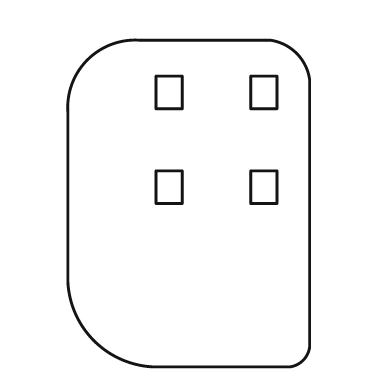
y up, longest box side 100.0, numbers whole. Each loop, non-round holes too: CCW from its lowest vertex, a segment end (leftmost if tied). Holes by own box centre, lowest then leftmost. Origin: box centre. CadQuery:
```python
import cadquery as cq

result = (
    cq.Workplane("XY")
    .moveTo(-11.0, -50.0)
    .lineTo(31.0, -50.0)
    .threePointArc((35.0, -48.0), (37.0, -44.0))
    .lineTo(37.0, 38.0)
    .threePointArc((33.0, 46.0), (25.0, 50.0))
    .lineTo(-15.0, 50.0)
    .threePointArc((-31.0, 44.0), (-37.0, 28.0))
    .lineTo(-37.0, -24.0)
    .threePointArc((-29.0, -42.0), (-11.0, -50.0))
    .close()
    .moveTo(-10.0, 0.0)
    .lineTo(-2.0, 0.0)
    .lineTo(-2.0, 10.0)
    .lineTo(-10.0, 10.0)
    .close()
    .moveTo(19.0, 0.0)
    .lineTo(27.0, 0.0)
    .lineTo(27.0, 10.0)
    .lineTo(19.0, 10.0)
    .close()
    .moveTo(-10.0, 29.0)
    .lineTo(-2.0, 29.0)
    .lineTo(-2.0, 39.0)
    .lineTo(-10.0, 39.0)
    .close()
    .moveTo(19.0, 29.0)
    .lineTo(27.0, 29.0)
    .lineTo(27.0, 39.0)
    .lineTo(19.0, 39.0)
    .close()
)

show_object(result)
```